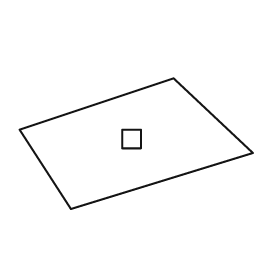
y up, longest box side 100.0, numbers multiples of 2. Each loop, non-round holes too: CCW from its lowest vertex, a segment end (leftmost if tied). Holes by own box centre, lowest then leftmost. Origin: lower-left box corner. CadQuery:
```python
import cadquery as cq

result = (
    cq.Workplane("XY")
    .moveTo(22.0, 0.0)
    .lineTo(100.0, 24.0)
    .lineTo(66.0, 56.0)
    .lineTo(0.0, 34.0)
    .close()
    .moveTo(44.0, 26.0)
    .lineTo(52.0, 26.0)
    .lineTo(52.0, 34.0)
    .lineTo(44.0, 34.0)
    .close()
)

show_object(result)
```